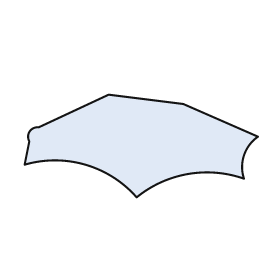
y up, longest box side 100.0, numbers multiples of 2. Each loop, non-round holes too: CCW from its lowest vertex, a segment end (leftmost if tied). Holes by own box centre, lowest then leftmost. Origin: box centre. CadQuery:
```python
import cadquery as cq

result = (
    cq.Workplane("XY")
    .moveTo(-2.0, -22.0)
    .threePointArc((20.0, -12.0), (44.0, -14.0))
    .threePointArc((44.0, -4.0), (50.0, 4.0))
    .lineTo(18.0, 18.0)
    .lineTo(-14.0, 22.0)
    .lineTo(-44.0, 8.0)
    .threePointArc((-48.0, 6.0), (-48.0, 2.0))
    .lineTo(-50.0, -8.0)
    .threePointArc((-24.0, -8.0), (-2.0, -22.0))
    .close()
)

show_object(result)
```